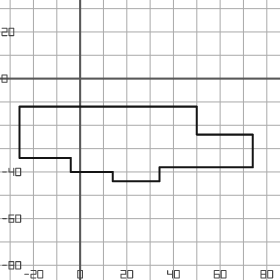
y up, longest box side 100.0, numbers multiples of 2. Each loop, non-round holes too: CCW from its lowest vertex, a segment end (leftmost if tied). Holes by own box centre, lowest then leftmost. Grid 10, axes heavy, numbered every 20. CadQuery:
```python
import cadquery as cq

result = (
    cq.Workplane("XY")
    .moveTo(14.0, -44.0)
    .lineTo(34.0, -44.0)
    .lineTo(34.0, -38.0)
    .lineTo(74.0, -38.0)
    .lineTo(74.0, -24.0)
    .lineTo(50.0, -24.0)
    .lineTo(50.0, -12.0)
    .lineTo(-26.0, -12.0)
    .lineTo(-26.0, -34.0)
    .lineTo(-4.0, -34.0)
    .lineTo(-4.0, -40.0)
    .lineTo(14.0, -40.0)
    .close()
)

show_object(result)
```